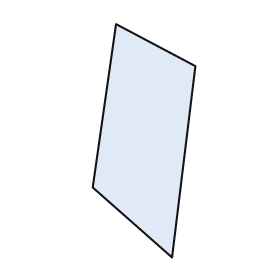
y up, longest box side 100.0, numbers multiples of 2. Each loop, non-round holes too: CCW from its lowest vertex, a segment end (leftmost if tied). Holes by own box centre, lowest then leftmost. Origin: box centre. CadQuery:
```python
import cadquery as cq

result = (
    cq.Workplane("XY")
    .moveTo(12.0, -50.0)
    .lineTo(22.0, 32.0)
    .lineTo(-12.0, 50.0)
    .lineTo(-22.0, -20.0)
    .close()
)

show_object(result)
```